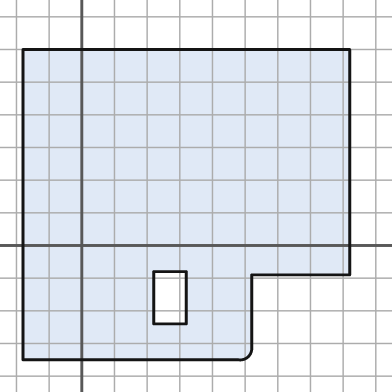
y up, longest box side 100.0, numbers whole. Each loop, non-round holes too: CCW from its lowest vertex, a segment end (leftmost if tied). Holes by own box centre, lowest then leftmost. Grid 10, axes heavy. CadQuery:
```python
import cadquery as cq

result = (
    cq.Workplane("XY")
    .moveTo(-18.0, -35.0)
    .lineTo(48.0, -35.0)
    .threePointArc((51.0, -34.0), (52.0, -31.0))
    .lineTo(52.0, -9.0)
    .lineTo(82.0, -9.0)
    .lineTo(82.0, 60.0)
    .lineTo(-18.0, 60.0)
    .close()
    .moveTo(22.0, -24.0)
    .lineTo(32.0, -24.0)
    .lineTo(32.0, -8.0)
    .lineTo(22.0, -8.0)
    .close()
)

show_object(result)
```